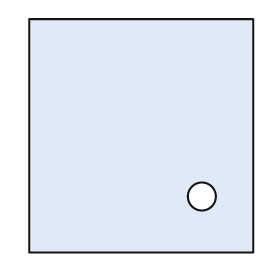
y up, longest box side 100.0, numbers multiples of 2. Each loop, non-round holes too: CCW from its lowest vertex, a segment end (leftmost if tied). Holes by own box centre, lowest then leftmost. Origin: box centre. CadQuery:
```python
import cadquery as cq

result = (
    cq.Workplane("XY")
    .moveTo(-48.0, -50.0)
    .lineTo(48.0, -50.0)
    .lineTo(48.0, 50.0)
    .lineTo(-48.0, 50.0)
    .close()
    .moveTo(26.0, -26.0)
    .circle(6.0)
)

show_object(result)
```